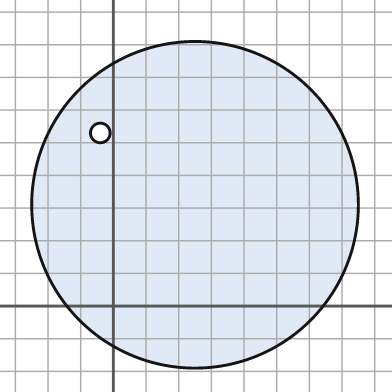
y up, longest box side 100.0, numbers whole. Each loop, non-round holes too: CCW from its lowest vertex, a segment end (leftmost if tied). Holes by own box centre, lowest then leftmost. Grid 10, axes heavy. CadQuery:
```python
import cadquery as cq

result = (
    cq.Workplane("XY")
    .moveTo(25.0, 31.0)
    .circle(50.0)
    .moveTo(-4.0, 53.0)
    .circle(3.0)
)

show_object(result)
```